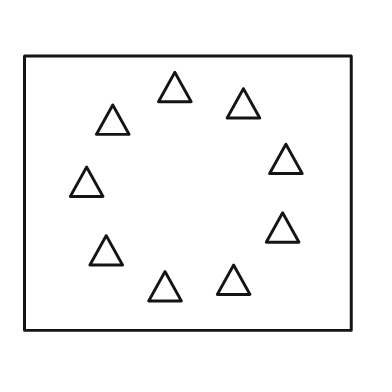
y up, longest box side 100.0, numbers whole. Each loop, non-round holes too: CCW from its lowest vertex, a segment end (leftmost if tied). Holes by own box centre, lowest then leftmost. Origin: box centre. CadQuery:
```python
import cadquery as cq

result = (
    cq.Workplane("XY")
    .moveTo(-50.0, -42.0)
    .lineTo(50.0, -42.0)
    .lineTo(50.0, 42.0)
    .lineTo(-50.0, 42.0)
    .close()
    .moveTo(-12.0, -33.0)
    .lineTo(-2.0, -33.0)
    .lineTo(-7.0, -24.0)
    .close()
    .moveTo(9.0, -31.0)
    .lineTo(19.0, -31.0)
    .lineTo(14.0, -22.0)
    .close()
    .moveTo(-30.0, -22.0)
    .lineTo(-20.0, -22.0)
    .lineTo(-25.0, -13.0)
    .close()
    .moveTo(24.0, -15.0)
    .lineTo(34.0, -15.0)
    .lineTo(29.0, -6.0)
    .close()
    .moveTo(-36.0, -1.0)
    .lineTo(-26.0, -1.0)
    .lineTo(-31.0, 8.0)
    .close()
    .moveTo(25.0, 6.0)
    .lineTo(35.0, 6.0)
    .lineTo(30.0, 15.0)
    .close()
    .moveTo(-28.0, 18.0)
    .lineTo(-18.0, 18.0)
    .lineTo(-23.0, 27.0)
    .close()
    .moveTo(12.0, 23.0)
    .lineTo(22.0, 23.0)
    .lineTo(17.0, 32.0)
    .close()
    .moveTo(-9.0, 28.0)
    .lineTo(1.0, 28.0)
    .lineTo(-4.0, 37.0)
    .close()
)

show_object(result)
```